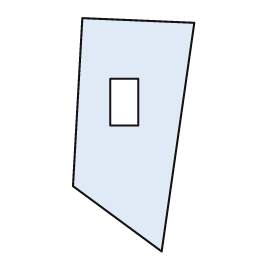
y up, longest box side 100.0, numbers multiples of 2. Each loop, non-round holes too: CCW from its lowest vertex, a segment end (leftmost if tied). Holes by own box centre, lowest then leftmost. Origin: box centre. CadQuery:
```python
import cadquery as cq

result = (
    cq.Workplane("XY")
    .moveTo(12.0, -50.0)
    .lineTo(26.0, 48.0)
    .lineTo(-22.0, 50.0)
    .lineTo(-26.0, -22.0)
    .close()
    .moveTo(-10.0, 4.0)
    .lineTo(2.0, 4.0)
    .lineTo(2.0, 24.0)
    .lineTo(-10.0, 24.0)
    .close()
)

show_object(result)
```